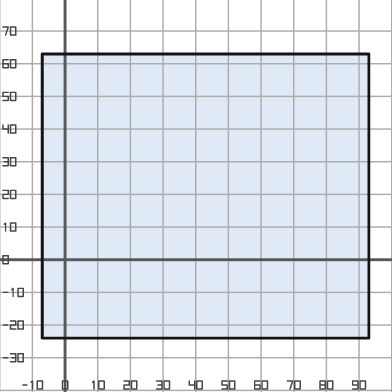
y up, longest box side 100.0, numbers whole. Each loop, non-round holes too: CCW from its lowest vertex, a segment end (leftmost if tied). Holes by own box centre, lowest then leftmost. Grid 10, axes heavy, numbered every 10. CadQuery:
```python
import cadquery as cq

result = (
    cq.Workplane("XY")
    .moveTo(-7.0, -24.0)
    .lineTo(93.0, -24.0)
    .lineTo(93.0, 63.0)
    .lineTo(-7.0, 63.0)
    .close()
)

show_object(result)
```